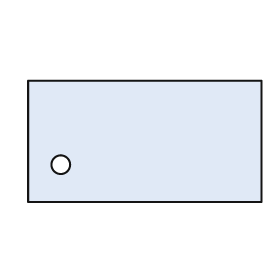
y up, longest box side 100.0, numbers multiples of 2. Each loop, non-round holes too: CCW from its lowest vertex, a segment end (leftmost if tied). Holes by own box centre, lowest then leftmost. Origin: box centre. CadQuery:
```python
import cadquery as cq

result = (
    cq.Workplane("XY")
    .moveTo(-50.0, -26.0)
    .lineTo(50.0, -26.0)
    .lineTo(50.0, 26.0)
    .lineTo(-50.0, 26.0)
    .close()
    .moveTo(-36.0, -10.0)
    .circle(4.0)
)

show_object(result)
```